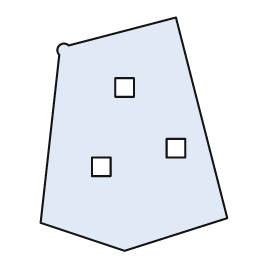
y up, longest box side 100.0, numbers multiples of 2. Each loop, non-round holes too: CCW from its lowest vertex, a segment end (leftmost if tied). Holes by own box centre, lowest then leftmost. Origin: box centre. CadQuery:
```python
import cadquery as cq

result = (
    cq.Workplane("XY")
    .moveTo(-4.0, -50.0)
    .lineTo(40.0, -36.0)
    .lineTo(18.0, 50.0)
    .lineTo(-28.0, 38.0)
    .threePointArc((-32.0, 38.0), (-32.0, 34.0))
    .lineTo(-40.0, -38.0)
    .close()
    .moveTo(-18.0, -18.0)
    .lineTo(-10.0, -18.0)
    .lineTo(-10.0, -10.0)
    .lineTo(-18.0, -10.0)
    .close()
    .moveTo(14.0, -10.0)
    .lineTo(22.0, -10.0)
    .lineTo(22.0, -2.0)
    .lineTo(14.0, -2.0)
    .close()
    .moveTo(-8.0, 16.0)
    .lineTo(0.0, 16.0)
    .lineTo(0.0, 24.0)
    .lineTo(-8.0, 24.0)
    .close()
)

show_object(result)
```